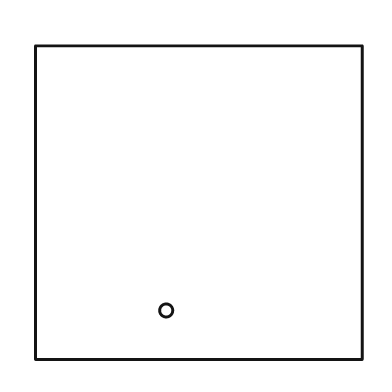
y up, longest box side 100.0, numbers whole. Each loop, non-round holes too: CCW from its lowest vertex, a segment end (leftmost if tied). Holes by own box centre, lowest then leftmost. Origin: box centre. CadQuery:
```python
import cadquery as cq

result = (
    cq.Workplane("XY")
    .moveTo(-50.0, -48.0)
    .lineTo(50.0, -48.0)
    .lineTo(50.0, 48.0)
    .lineTo(-50.0, 48.0)
    .close()
    .moveTo(-10.0, -33.0)
    .circle(2.0)
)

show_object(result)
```